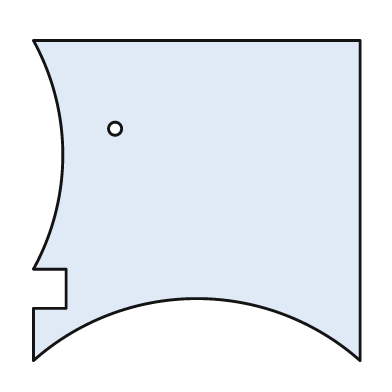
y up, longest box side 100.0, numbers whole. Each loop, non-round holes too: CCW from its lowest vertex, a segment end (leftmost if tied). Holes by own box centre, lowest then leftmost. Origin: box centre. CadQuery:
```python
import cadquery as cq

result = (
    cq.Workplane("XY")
    .moveTo(-50.0, -49.0)
    .threePointArc((0.0, -30.0), (50.0, -49.0))
    .lineTo(50.0, 49.0)
    .lineTo(-50.0, 49.0)
    .threePointArc((-41.0, 14.0), (-50.0, -21.0))
    .lineTo(-40.0, -21.0)
    .lineTo(-40.0, -33.0)
    .lineTo(-50.0, -33.0)
    .close()
    .moveTo(-25.0, 22.0)
    .circle(2.0)
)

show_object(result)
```